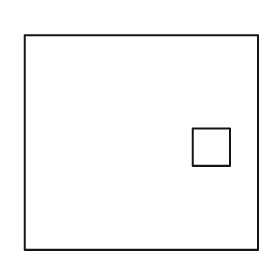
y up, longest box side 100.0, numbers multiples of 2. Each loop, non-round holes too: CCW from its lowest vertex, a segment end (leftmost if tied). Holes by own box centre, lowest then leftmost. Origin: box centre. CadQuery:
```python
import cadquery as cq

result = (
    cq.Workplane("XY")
    .moveTo(-50.0, -46.0)
    .lineTo(50.0, -46.0)
    .lineTo(50.0, 46.0)
    .lineTo(-50.0, 46.0)
    .close()
    .moveTo(22.0, -10.0)
    .lineTo(38.0, -10.0)
    .lineTo(38.0, 6.0)
    .lineTo(22.0, 6.0)
    .close()
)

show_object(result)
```